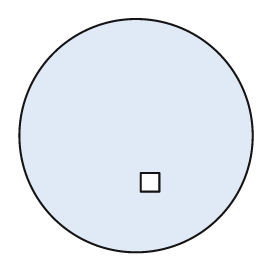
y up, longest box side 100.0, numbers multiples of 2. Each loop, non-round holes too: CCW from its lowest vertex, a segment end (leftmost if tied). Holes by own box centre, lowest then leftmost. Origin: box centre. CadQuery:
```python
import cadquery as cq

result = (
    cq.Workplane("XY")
    .moveTo(0.0, 0.0)
    .circle(50.0)
    .moveTo(2.0, -24.0)
    .lineTo(10.0, -24.0)
    .lineTo(10.0, -16.0)
    .lineTo(2.0, -16.0)
    .close()
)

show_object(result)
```